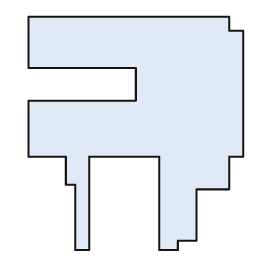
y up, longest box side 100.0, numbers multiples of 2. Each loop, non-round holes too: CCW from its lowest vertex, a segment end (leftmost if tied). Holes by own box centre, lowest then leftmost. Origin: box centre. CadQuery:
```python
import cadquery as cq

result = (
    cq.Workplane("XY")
    .moveTo(-26.0, -50.0)
    .lineTo(-20.0, -50.0)
    .lineTo(-20.0, -10.0)
    .lineTo(10.0, -10.0)
    .lineTo(10.0, -50.0)
    .lineTo(18.0, -50.0)
    .lineTo(18.0, -46.0)
    .lineTo(26.0, -46.0)
    .lineTo(26.0, -24.0)
    .lineTo(40.0, -24.0)
    .lineTo(40.0, -10.0)
    .lineTo(46.0, -10.0)
    .lineTo(46.0, 44.0)
    .lineTo(40.0, 44.0)
    .lineTo(40.0, 50.0)
    .lineTo(-46.0, 50.0)
    .lineTo(-46.0, 28.0)
    .lineTo(0.0, 28.0)
    .lineTo(0.0, 14.0)
    .lineTo(-46.0, 14.0)
    .lineTo(-46.0, -10.0)
    .lineTo(-30.0, -10.0)
    .lineTo(-30.0, -22.0)
    .lineTo(-26.0, -22.0)
    .close()
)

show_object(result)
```